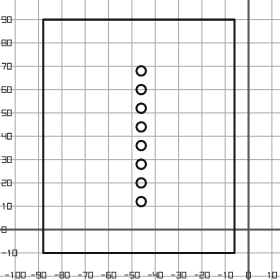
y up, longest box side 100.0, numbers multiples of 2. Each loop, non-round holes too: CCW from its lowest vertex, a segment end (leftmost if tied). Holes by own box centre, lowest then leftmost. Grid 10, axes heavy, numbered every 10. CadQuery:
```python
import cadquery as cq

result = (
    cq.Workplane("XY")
    .moveTo(-88.0, -10.0)
    .lineTo(-6.0, -10.0)
    .lineTo(-6.0, 90.0)
    .lineTo(-88.0, 90.0)
    .close()
    .moveTo(-46.0, 12.0)
    .circle(2.0)
    .moveTo(-46.0, 20.0)
    .circle(2.0)
    .moveTo(-46.0, 28.0)
    .circle(2.0)
    .moveTo(-46.0, 36.0)
    .circle(2.0)
    .moveTo(-46.0, 44.0)
    .circle(2.0)
    .moveTo(-46.0, 52.0)
    .circle(2.0)
    .moveTo(-46.0, 60.0)
    .circle(2.0)
    .moveTo(-46.0, 68.0)
    .circle(2.0)
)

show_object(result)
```